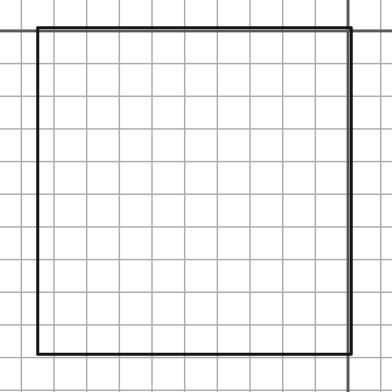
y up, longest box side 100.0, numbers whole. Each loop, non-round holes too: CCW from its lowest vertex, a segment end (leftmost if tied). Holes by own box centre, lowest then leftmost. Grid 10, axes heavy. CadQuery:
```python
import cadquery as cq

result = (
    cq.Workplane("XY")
    .moveTo(-95.0, -99.0)
    .lineTo(1.0, -99.0)
    .lineTo(1.0, 1.0)
    .lineTo(-95.0, 1.0)
    .close()
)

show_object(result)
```